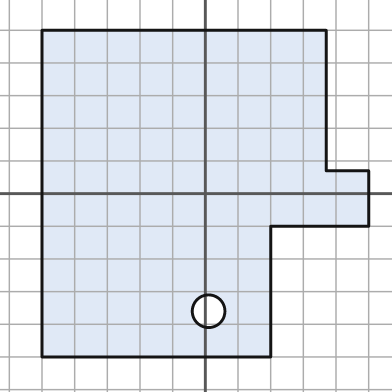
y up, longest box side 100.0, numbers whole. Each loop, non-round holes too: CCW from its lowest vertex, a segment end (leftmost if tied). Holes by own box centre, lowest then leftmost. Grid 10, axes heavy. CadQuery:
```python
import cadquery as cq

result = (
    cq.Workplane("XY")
    .moveTo(-50.0, -50.0)
    .lineTo(20.0, -50.0)
    .lineTo(20.0, -10.0)
    .lineTo(50.0, -10.0)
    .lineTo(50.0, 7.0)
    .lineTo(37.0, 7.0)
    .lineTo(37.0, 50.0)
    .lineTo(-50.0, 50.0)
    .close()
    .moveTo(1.0, -36.0)
    .circle(5.0)
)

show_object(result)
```